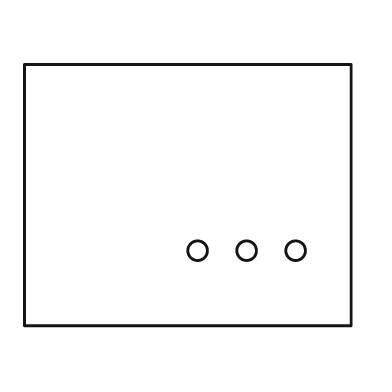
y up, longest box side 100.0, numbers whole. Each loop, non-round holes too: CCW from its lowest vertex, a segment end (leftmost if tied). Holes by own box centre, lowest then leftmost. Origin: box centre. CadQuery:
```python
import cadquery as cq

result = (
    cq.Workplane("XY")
    .moveTo(-50.0, -40.0)
    .lineTo(50.0, -40.0)
    .lineTo(50.0, 40.0)
    .lineTo(-50.0, 40.0)
    .close()
    .moveTo(3.0, -17.0)
    .circle(3.0)
    .moveTo(18.0, -17.0)
    .circle(3.0)
    .moveTo(33.0, -17.0)
    .circle(3.0)
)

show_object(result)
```